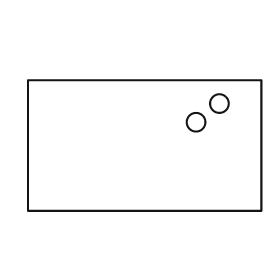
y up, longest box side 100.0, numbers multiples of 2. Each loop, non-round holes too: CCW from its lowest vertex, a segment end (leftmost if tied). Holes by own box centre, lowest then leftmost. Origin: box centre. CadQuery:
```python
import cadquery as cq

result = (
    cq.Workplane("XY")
    .moveTo(-50.0, -28.0)
    .lineTo(50.0, -28.0)
    .lineTo(50.0, 28.0)
    .lineTo(-50.0, 28.0)
    .close()
    .moveTo(22.0, 10.0)
    .circle(4.0)
    .moveTo(32.0, 18.0)
    .circle(4.0)
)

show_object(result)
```